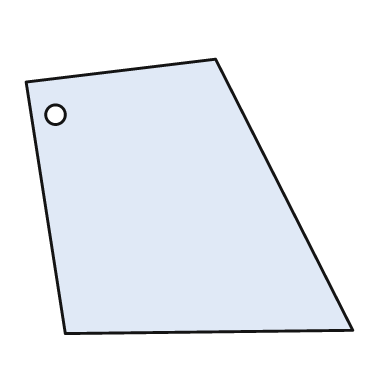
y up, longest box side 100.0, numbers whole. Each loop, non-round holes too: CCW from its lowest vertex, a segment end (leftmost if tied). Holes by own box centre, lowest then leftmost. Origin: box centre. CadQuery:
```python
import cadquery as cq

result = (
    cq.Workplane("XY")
    .moveTo(-38.0, -42.0)
    .lineTo(50.0, -41.0)
    .lineTo(8.0, 42.0)
    .lineTo(-50.0, 35.0)
    .close()
    .moveTo(-41.0, 25.0)
    .circle(3.0)
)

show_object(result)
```